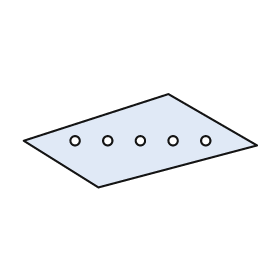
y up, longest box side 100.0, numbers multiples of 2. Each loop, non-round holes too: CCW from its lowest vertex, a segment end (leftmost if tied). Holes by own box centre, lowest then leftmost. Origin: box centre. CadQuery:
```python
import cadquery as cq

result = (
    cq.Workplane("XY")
    .moveTo(-18.0, -20.0)
    .lineTo(50.0, -2.0)
    .lineTo(12.0, 20.0)
    .lineTo(-50.0, 0.0)
    .close()
    .moveTo(-28.0, 0.0)
    .circle(2.0)
    .moveTo(-14.0, 0.0)
    .circle(2.0)
    .moveTo(0.0, 0.0)
    .circle(2.0)
    .moveTo(14.0, 0.0)
    .circle(2.0)
    .moveTo(28.0, 0.0)
    .circle(2.0)
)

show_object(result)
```